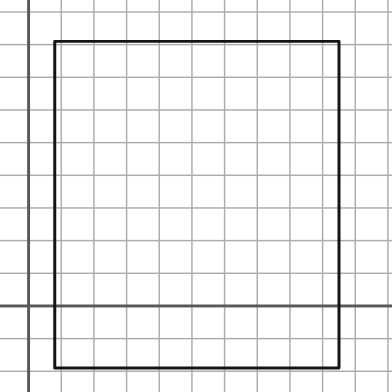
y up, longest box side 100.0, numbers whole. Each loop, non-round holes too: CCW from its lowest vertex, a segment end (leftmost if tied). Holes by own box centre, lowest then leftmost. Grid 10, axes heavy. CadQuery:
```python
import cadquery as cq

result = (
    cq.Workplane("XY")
    .moveTo(8.0, -19.0)
    .lineTo(95.0, -19.0)
    .lineTo(95.0, 81.0)
    .lineTo(8.0, 81.0)
    .close()
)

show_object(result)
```